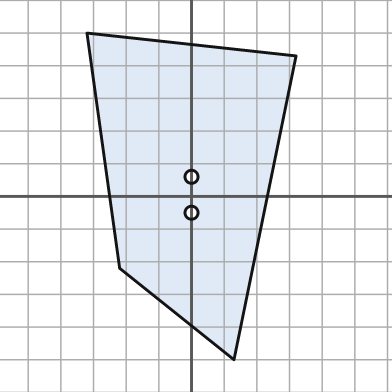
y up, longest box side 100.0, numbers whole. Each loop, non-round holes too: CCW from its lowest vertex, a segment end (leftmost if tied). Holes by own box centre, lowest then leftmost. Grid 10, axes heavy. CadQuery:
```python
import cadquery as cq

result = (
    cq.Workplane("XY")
    .moveTo(13.0, -50.0)
    .lineTo(32.0, 43.0)
    .lineTo(-32.0, 50.0)
    .lineTo(-22.0, -22.0)
    .close()
    .moveTo(0.0, -5.0)
    .circle(2.0)
    .moveTo(0.0, 6.0)
    .circle(2.0)
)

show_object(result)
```